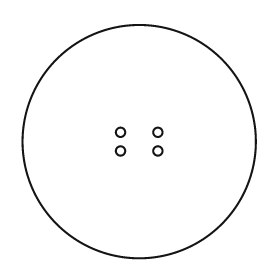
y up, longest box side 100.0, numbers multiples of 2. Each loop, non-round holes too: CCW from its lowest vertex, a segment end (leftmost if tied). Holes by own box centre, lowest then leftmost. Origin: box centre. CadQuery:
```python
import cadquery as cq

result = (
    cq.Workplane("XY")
    .moveTo(0.0, 0.0)
    .circle(50.0)
    .moveTo(-8.0, -4.0)
    .circle(2.0)
    .moveTo(8.0, -4.0)
    .circle(2.0)
    .moveTo(-8.0, 4.0)
    .circle(2.0)
    .moveTo(8.0, 4.0)
    .circle(2.0)
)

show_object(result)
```